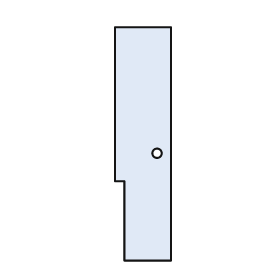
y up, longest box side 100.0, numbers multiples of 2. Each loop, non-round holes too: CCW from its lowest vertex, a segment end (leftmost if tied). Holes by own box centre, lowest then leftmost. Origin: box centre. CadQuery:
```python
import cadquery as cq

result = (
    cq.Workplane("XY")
    .moveTo(-8.0, -50.0)
    .lineTo(12.0, -50.0)
    .lineTo(12.0, 50.0)
    .lineTo(-12.0, 50.0)
    .lineTo(-12.0, -16.0)
    .lineTo(-8.0, -16.0)
    .close()
    .moveTo(6.0, -4.0)
    .circle(2.0)
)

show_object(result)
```